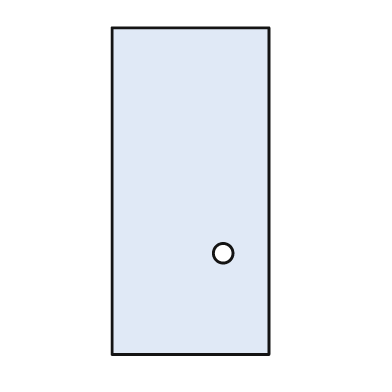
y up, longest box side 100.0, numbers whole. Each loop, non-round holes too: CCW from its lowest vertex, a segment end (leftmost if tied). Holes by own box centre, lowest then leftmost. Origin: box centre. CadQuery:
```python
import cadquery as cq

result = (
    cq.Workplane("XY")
    .moveTo(-24.0, -50.0)
    .lineTo(24.0, -50.0)
    .lineTo(24.0, 50.0)
    .lineTo(-24.0, 50.0)
    .close()
    .moveTo(10.0, -19.0)
    .circle(3.0)
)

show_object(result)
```